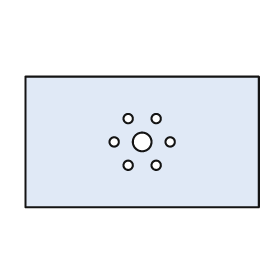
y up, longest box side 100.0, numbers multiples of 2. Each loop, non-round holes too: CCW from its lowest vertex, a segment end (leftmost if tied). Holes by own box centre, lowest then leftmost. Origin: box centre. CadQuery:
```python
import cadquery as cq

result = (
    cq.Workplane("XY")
    .moveTo(-50.0, -28.0)
    .lineTo(50.0, -28.0)
    .lineTo(50.0, 28.0)
    .lineTo(-50.0, 28.0)
    .close()
    .moveTo(-6.0, -10.0)
    .circle(2.0)
    .moveTo(6.0, -10.0)
    .circle(2.0)
    .moveTo(-12.0, 0.0)
    .circle(2.0)
    .moveTo(0.0, 0.0)
    .circle(4.0)
    .moveTo(12.0, 0.0)
    .circle(2.0)
    .moveTo(-6.0, 10.0)
    .circle(2.0)
    .moveTo(6.0, 10.0)
    .circle(2.0)
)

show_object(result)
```